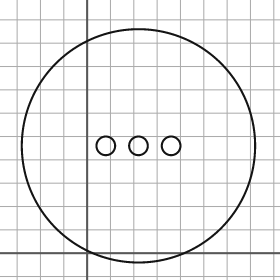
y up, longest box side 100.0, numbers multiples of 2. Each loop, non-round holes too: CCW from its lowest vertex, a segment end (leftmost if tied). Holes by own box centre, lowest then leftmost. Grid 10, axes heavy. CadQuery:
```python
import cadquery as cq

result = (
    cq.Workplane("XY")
    .moveTo(22.0, 46.0)
    .circle(50.0)
    .moveTo(8.0, 46.0)
    .circle(4.0)
    .moveTo(22.0, 46.0)
    .circle(4.0)
    .moveTo(36.0, 46.0)
    .circle(4.0)
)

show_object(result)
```